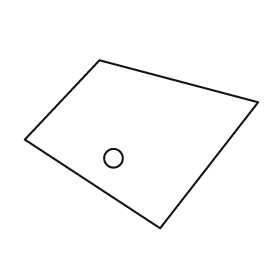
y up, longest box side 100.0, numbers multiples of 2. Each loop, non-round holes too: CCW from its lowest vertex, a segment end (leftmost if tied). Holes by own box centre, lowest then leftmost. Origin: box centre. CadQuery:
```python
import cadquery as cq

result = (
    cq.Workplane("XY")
    .moveTo(8.0, -36.0)
    .lineTo(50.0, 18.0)
    .lineTo(-18.0, 36.0)
    .lineTo(-50.0, 2.0)
    .close()
    .moveTo(-12.0, -6.0)
    .circle(4.0)
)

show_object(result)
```